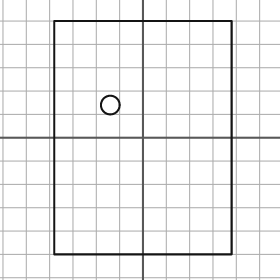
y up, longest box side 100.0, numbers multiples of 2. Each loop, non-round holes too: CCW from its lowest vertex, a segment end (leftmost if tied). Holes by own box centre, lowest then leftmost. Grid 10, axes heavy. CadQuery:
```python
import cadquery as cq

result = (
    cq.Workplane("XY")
    .moveTo(-38.0, -50.0)
    .lineTo(38.0, -50.0)
    .lineTo(38.0, 50.0)
    .lineTo(-38.0, 50.0)
    .close()
    .moveTo(-14.0, 14.0)
    .circle(4.0)
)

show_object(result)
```